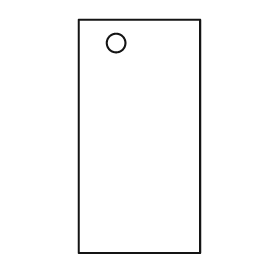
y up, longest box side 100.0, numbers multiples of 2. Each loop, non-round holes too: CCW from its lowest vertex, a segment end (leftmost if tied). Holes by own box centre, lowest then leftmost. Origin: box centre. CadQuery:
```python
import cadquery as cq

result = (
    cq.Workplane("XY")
    .moveTo(-26.0, -50.0)
    .lineTo(26.0, -50.0)
    .lineTo(26.0, 50.0)
    .lineTo(-26.0, 50.0)
    .close()
    .moveTo(-10.0, 40.0)
    .circle(4.0)
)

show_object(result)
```